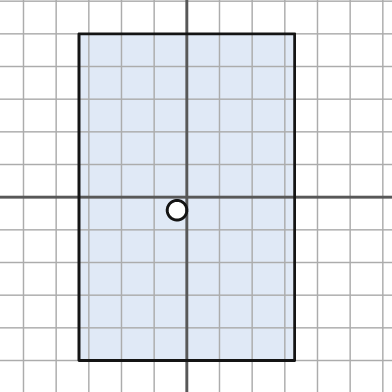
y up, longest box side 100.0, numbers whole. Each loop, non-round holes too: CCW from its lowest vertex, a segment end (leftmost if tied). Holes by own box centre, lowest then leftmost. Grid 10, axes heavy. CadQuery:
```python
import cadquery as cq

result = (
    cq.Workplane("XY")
    .moveTo(-33.0, -50.0)
    .lineTo(33.0, -50.0)
    .lineTo(33.0, 50.0)
    .lineTo(-33.0, 50.0)
    .close()
    .moveTo(-3.0, -4.0)
    .circle(3.0)
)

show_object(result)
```